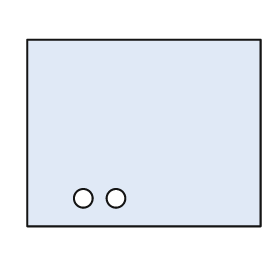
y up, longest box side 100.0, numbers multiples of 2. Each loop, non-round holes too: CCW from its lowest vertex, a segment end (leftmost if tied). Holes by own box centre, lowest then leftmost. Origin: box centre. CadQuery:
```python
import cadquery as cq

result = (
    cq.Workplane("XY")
    .moveTo(-50.0, -40.0)
    .lineTo(50.0, -40.0)
    .lineTo(50.0, 40.0)
    .lineTo(-50.0, 40.0)
    .close()
    .moveTo(-26.0, -28.0)
    .circle(4.0)
    .moveTo(-12.0, -28.0)
    .circle(4.0)
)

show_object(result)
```